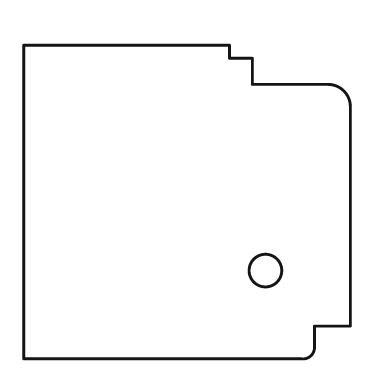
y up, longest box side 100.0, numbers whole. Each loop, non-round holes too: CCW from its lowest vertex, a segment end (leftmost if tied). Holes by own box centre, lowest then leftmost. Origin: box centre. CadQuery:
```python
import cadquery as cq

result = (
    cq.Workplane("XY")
    .moveTo(-50.0, -48.0)
    .lineTo(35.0, -48.0)
    .threePointArc((38.0, -47.0), (39.0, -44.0))
    .lineTo(39.0, -38.0)
    .lineTo(50.0, -38.0)
    .lineTo(50.0, 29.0)
    .threePointArc((48.0, 34.0), (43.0, 36.0))
    .lineTo(20.0, 36.0)
    .lineTo(20.0, 44.0)
    .lineTo(13.0, 44.0)
    .lineTo(13.0, 48.0)
    .lineTo(-50.0, 48.0)
    .close()
    .moveTo(24.0, -21.0)
    .circle(5.0)
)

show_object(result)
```